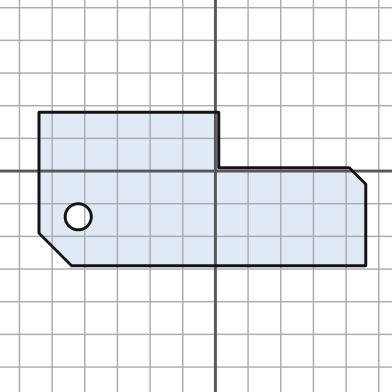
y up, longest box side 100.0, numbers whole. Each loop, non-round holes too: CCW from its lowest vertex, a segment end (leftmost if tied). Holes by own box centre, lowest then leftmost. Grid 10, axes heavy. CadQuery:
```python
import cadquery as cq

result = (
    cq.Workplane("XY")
    .moveTo(-44.0, -29.0)
    .lineTo(46.0, -29.0)
    .lineTo(46.0, -4.0)
    .lineTo(41.0, 1.0)
    .lineTo(1.0, 1.0)
    .lineTo(1.0, 18.0)
    .lineTo(-54.0, 18.0)
    .lineTo(-54.0, -19.0)
    .close()
    .moveTo(-42.0, -14.0)
    .circle(4.0)
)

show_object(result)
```